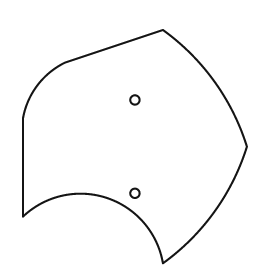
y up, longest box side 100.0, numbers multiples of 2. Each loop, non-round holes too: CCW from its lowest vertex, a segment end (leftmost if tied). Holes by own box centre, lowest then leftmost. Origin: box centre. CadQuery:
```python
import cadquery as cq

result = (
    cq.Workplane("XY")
    .moveTo(12.0, -50.0)
    .threePointArc((34.0, -28.0), (48.0, 0.0))
    .threePointArc((34.0, 28.0), (12.0, 50.0))
    .lineTo(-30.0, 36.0)
    .threePointArc((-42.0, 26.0), (-48.0, 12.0))
    .lineTo(-48.0, -30.0)
    .threePointArc((-12.0, -22.0), (12.0, -50.0))
    .close()
    .moveTo(0.0, -20.0)
    .circle(2.0)
    .moveTo(0.0, 20.0)
    .circle(2.0)
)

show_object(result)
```